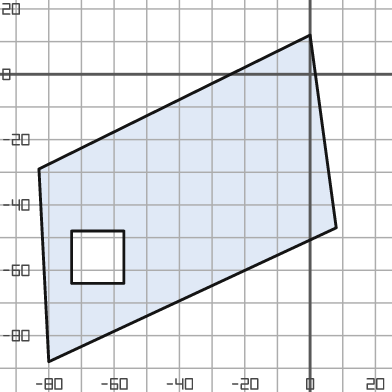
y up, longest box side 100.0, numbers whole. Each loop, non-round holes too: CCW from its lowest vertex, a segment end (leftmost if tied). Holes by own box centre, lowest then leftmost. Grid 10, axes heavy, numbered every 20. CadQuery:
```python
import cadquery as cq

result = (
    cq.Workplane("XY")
    .moveTo(-80.0, -88.0)
    .lineTo(8.0, -47.0)
    .lineTo(0.0, 12.0)
    .lineTo(-83.0, -29.0)
    .close()
    .moveTo(-73.0, -64.0)
    .lineTo(-57.0, -64.0)
    .lineTo(-57.0, -48.0)
    .lineTo(-73.0, -48.0)
    .close()
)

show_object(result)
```